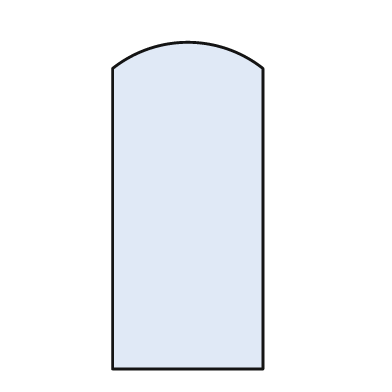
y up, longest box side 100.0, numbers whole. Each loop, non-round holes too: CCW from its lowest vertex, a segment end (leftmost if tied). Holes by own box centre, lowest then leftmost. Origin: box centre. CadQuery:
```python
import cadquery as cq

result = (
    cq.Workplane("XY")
    .moveTo(-23.0, -50.0)
    .lineTo(23.0, -50.0)
    .lineTo(23.0, 42.0)
    .threePointArc((0.0, 50.0), (-23.0, 42.0))
    .close()
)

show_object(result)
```